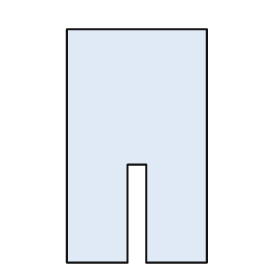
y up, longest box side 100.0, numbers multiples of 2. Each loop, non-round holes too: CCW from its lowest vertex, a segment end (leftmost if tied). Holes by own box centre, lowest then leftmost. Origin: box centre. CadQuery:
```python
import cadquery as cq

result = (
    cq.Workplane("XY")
    .moveTo(-30.0, -50.0)
    .lineTo(-4.0, -50.0)
    .lineTo(-4.0, -8.0)
    .lineTo(4.0, -8.0)
    .lineTo(4.0, -50.0)
    .lineTo(30.0, -50.0)
    .lineTo(30.0, 50.0)
    .lineTo(-30.0, 50.0)
    .close()
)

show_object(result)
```